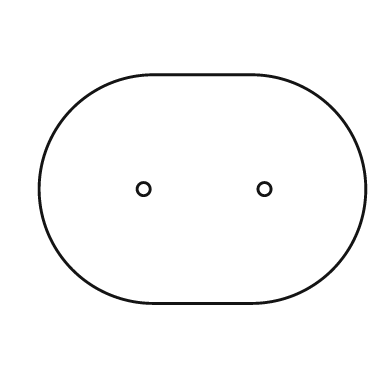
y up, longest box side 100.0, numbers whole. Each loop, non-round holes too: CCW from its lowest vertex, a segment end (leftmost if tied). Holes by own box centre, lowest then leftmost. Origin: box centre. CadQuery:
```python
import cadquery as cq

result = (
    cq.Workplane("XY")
    .moveTo(-15.0, -35.0)
    .lineTo(15.0, -35.0)
    .threePointArc((50.0, 0.0), (15.0, 35.0))
    .lineTo(-15.0, 35.0)
    .threePointArc((-50.0, 0.0), (-15.0, -35.0))
    .close()
    .moveTo(-18.0, 0.0)
    .circle(2.0)
    .moveTo(19.0, 0.0)
    .circle(2.0)
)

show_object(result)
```